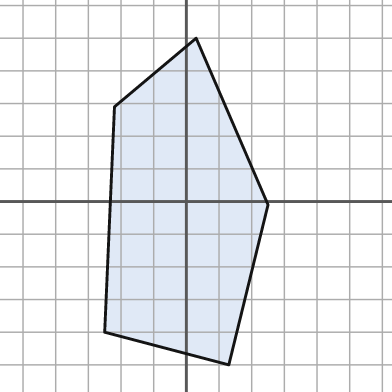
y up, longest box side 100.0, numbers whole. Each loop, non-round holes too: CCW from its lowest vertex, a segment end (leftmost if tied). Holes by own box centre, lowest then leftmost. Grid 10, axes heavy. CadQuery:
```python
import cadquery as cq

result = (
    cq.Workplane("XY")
    .moveTo(13.0, -50.0)
    .lineTo(25.0, -1.0)
    .lineTo(3.0, 50.0)
    .lineTo(-22.0, 29.0)
    .lineTo(-25.0, -40.0)
    .close()
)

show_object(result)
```